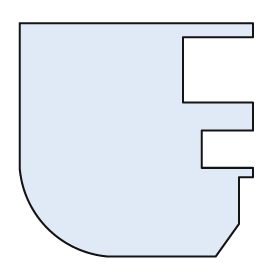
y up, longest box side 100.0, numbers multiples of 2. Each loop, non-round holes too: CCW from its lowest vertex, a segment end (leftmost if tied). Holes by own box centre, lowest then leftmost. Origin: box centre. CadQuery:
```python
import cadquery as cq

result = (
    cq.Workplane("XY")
    .moveTo(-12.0, -50.0)
    .lineTo(34.0, -50.0)
    .lineTo(44.0, -36.0)
    .lineTo(44.0, -16.0)
    .lineTo(50.0, -16.0)
    .lineTo(50.0, -12.0)
    .lineTo(28.0, -12.0)
    .lineTo(28.0, 4.0)
    .lineTo(50.0, 4.0)
    .lineTo(50.0, 16.0)
    .lineTo(20.0, 16.0)
    .lineTo(20.0, 44.0)
    .lineTo(50.0, 44.0)
    .lineTo(50.0, 50.0)
    .lineTo(-50.0, 50.0)
    .lineTo(-50.0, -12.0)
    .threePointArc((-38.0, -38.0), (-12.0, -50.0))
    .close()
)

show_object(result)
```